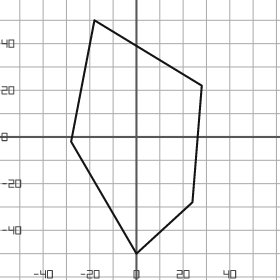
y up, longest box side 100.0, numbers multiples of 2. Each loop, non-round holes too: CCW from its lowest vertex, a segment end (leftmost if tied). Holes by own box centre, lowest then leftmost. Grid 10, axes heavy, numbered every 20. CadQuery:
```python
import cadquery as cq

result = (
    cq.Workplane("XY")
    .moveTo(0.0, -50.0)
    .lineTo(24.0, -28.0)
    .lineTo(28.0, 22.0)
    .lineTo(-18.0, 50.0)
    .lineTo(-28.0, -2.0)
    .close()
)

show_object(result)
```